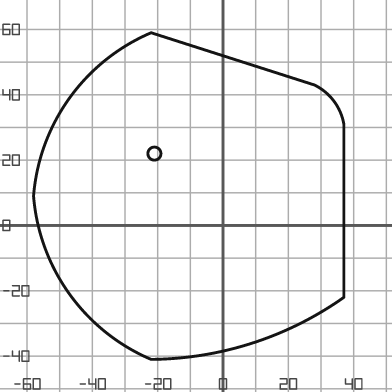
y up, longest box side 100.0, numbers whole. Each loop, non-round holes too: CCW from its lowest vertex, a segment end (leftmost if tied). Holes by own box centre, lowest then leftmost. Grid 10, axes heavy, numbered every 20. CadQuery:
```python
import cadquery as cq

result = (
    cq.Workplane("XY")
    .moveTo(-22.0, -41.0)
    .threePointArc((9.0, -36.0), (37.0, -22.0))
    .lineTo(37.0, 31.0)
    .threePointArc((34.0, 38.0), (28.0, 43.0))
    .lineTo(-22.0, 59.0)
    .threePointArc((-47.0, 39.0), (-58.0, 9.0))
    .threePointArc((-47.0, -21.0), (-22.0, -41.0))
    .close()
    .moveTo(-21.0, 22.0)
    .circle(2.0)
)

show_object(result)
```